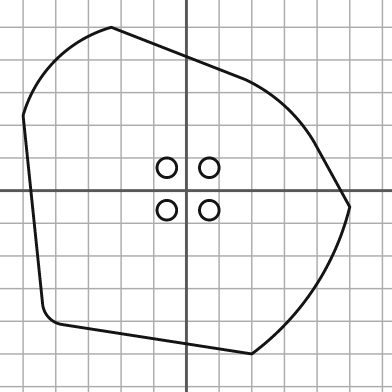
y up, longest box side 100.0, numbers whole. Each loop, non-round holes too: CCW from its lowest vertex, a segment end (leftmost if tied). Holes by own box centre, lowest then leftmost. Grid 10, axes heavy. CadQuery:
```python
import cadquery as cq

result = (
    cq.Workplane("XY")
    .moveTo(20.0, -50.0)
    .threePointArc((39.0, -30.0), (50.0, -5.0))
    .lineTo(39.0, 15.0)
    .threePointArc((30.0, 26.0), (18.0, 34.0))
    .lineTo(-23.0, 50.0)
    .threePointArc((-40.0, 40.0), (-50.0, 23.0))
    .lineTo(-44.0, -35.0)
    .threePointArc((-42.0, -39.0), (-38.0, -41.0))
    .close()
    .moveTo(-6.0, -6.0)
    .circle(3.0)
    .moveTo(7.0, -6.0)
    .circle(3.0)
    .moveTo(-6.0, 7.0)
    .circle(3.0)
    .moveTo(7.0, 7.0)
    .circle(3.0)
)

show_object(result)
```